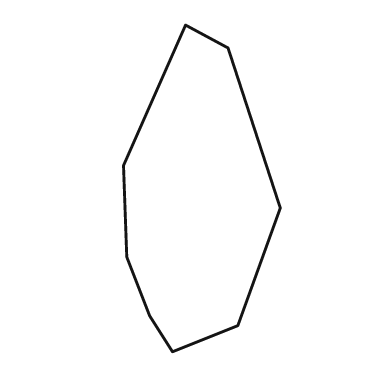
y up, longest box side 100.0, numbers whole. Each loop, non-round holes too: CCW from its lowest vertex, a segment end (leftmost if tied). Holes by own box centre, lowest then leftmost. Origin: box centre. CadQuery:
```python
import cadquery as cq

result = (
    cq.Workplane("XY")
    .moveTo(-9.0, -50.0)
    .lineTo(11.0, -42.0)
    .lineTo(24.0, -6.0)
    .lineTo(8.0, 43.0)
    .lineTo(-5.0, 50.0)
    .lineTo(-24.0, 7.0)
    .lineTo(-23.0, -21.0)
    .lineTo(-16.0, -39.0)
    .close()
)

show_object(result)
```